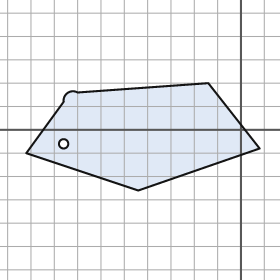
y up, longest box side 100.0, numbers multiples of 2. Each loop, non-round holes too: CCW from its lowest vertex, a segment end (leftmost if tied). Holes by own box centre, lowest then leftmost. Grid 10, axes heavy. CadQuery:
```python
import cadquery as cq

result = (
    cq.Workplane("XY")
    .moveTo(-44.0, -26.0)
    .lineTo(8.0, -8.0)
    .lineTo(-14.0, 20.0)
    .lineTo(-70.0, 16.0)
    .threePointArc((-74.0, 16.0), (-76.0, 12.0))
    .lineTo(-92.0, -10.0)
    .close()
    .moveTo(-76.0, -6.0)
    .circle(2.0)
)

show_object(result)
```